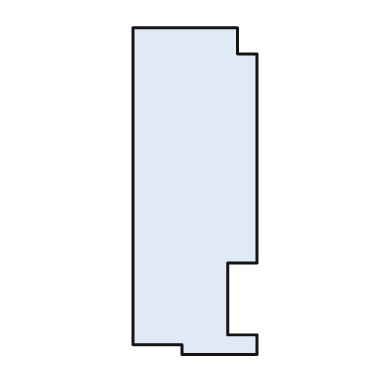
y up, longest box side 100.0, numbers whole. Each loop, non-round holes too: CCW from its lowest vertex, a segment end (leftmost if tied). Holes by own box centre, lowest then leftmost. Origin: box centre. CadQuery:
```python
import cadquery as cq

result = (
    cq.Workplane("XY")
    .moveTo(-4.0, -50.0)
    .lineTo(19.0, -50.0)
    .lineTo(19.0, -44.0)
    .lineTo(10.0, -44.0)
    .lineTo(10.0, -22.0)
    .lineTo(19.0, -22.0)
    .lineTo(19.0, 42.0)
    .lineTo(13.0, 42.0)
    .lineTo(13.0, 50.0)
    .lineTo(-19.0, 50.0)
    .lineTo(-19.0, -47.0)
    .lineTo(-4.0, -47.0)
    .close()
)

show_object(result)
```